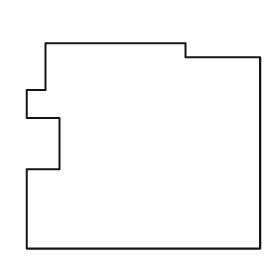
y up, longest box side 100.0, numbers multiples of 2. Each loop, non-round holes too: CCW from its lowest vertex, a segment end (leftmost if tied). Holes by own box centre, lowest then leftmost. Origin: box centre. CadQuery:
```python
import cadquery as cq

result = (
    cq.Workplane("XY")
    .moveTo(-50.0, -44.0)
    .lineTo(50.0, -44.0)
    .lineTo(50.0, 38.0)
    .lineTo(18.0, 38.0)
    .lineTo(18.0, 44.0)
    .lineTo(-42.0, 44.0)
    .lineTo(-42.0, 24.0)
    .lineTo(-50.0, 24.0)
    .lineTo(-50.0, 12.0)
    .lineTo(-36.0, 12.0)
    .lineTo(-36.0, -10.0)
    .lineTo(-50.0, -10.0)
    .close()
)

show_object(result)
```